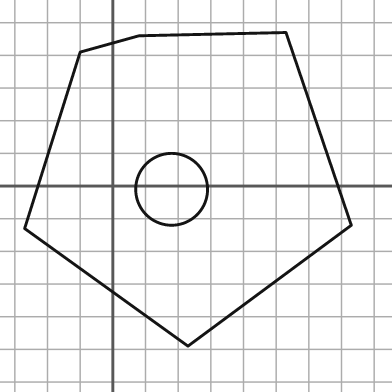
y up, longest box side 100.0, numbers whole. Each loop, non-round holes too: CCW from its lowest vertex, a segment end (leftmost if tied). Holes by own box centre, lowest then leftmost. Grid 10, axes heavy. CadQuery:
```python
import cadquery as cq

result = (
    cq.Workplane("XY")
    .moveTo(23.0, -49.0)
    .lineTo(73.0, -12.0)
    .lineTo(53.0, 47.0)
    .lineTo(8.0, 46.0)
    .lineTo(-10.0, 41.0)
    .lineTo(-27.0, -13.0)
    .close()
    .moveTo(18.0, -1.0)
    .circle(11.0)
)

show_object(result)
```